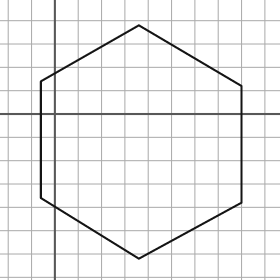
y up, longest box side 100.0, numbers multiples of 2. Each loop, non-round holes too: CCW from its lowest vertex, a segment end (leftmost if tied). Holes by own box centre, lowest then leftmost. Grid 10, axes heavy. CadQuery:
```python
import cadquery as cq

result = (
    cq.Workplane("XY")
    .moveTo(36.0, -62.0)
    .lineTo(80.0, -38.0)
    .lineTo(80.0, 12.0)
    .lineTo(36.0, 38.0)
    .lineTo(-6.0, 14.0)
    .lineTo(-6.0, -36.0)
    .close()
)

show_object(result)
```